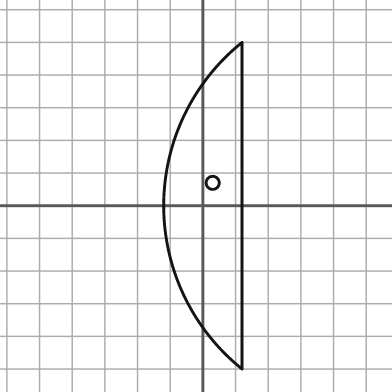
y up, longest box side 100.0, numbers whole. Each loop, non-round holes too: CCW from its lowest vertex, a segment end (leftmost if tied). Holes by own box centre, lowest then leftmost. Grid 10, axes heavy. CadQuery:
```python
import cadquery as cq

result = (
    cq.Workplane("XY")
    .moveTo(12.0, -50.0)
    .lineTo(12.0, 50.0)
    .threePointArc((-12.0, 0.0), (12.0, -50.0))
    .close()
    .moveTo(3.0, 7.0)
    .circle(2.0)
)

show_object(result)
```